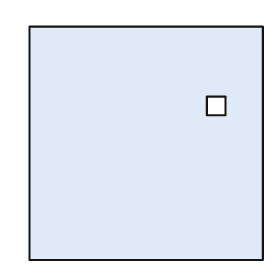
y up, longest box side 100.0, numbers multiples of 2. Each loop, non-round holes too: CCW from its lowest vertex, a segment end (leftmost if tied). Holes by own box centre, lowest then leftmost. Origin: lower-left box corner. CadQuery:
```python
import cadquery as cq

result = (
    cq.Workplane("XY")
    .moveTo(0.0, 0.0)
    .lineTo(100.0, 0.0)
    .lineTo(100.0, 100.0)
    .lineTo(0.0, 100.0)
    .close()
    .moveTo(76.0, 62.0)
    .lineTo(84.0, 62.0)
    .lineTo(84.0, 70.0)
    .lineTo(76.0, 70.0)
    .close()
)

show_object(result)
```